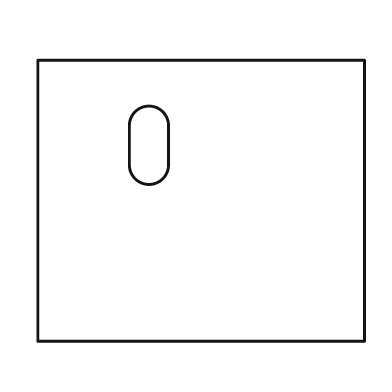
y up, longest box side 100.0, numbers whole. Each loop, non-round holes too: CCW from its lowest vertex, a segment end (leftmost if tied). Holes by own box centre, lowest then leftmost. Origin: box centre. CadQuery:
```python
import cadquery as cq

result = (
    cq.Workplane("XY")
    .moveTo(-50.0, -43.0)
    .lineTo(50.0, -43.0)
    .lineTo(50.0, 43.0)
    .lineTo(-50.0, 43.0)
    .close()
    .moveTo(-22.0, 11.0)
    .threePointArc((-16.0, 5.0), (-10.0, 11.0))
    .lineTo(-10.0, 23.0)
    .threePointArc((-16.0, 29.0), (-22.0, 23.0))
    .close()
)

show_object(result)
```